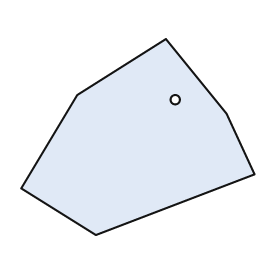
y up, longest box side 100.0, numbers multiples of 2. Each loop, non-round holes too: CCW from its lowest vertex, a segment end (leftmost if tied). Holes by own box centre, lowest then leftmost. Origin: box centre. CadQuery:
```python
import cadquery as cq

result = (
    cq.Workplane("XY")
    .moveTo(-18.0, -42.0)
    .lineTo(50.0, -16.0)
    .lineTo(38.0, 10.0)
    .lineTo(12.0, 42.0)
    .lineTo(-26.0, 18.0)
    .lineTo(-50.0, -22.0)
    .close()
    .moveTo(16.0, 16.0)
    .circle(2.0)
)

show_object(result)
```